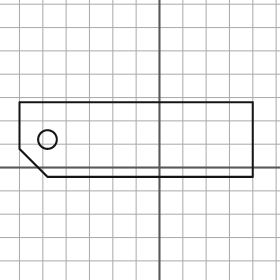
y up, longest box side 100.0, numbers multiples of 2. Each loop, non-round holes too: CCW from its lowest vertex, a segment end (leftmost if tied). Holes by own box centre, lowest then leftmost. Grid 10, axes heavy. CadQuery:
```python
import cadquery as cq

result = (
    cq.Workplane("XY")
    .moveTo(-48.0, -4.0)
    .lineTo(40.0, -4.0)
    .lineTo(40.0, 28.0)
    .lineTo(-60.0, 28.0)
    .lineTo(-60.0, 8.0)
    .close()
    .moveTo(-48.0, 12.0)
    .circle(4.0)
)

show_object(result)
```